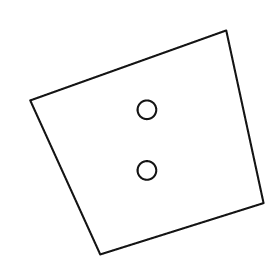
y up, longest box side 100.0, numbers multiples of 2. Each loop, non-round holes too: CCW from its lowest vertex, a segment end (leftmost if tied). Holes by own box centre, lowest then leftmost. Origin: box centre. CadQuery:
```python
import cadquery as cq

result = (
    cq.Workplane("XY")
    .moveTo(-20.0, -48.0)
    .lineTo(50.0, -26.0)
    .lineTo(34.0, 48.0)
    .lineTo(-50.0, 18.0)
    .close()
    .moveTo(0.0, -12.0)
    .circle(4.0)
    .moveTo(0.0, 14.0)
    .circle(4.0)
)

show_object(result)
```